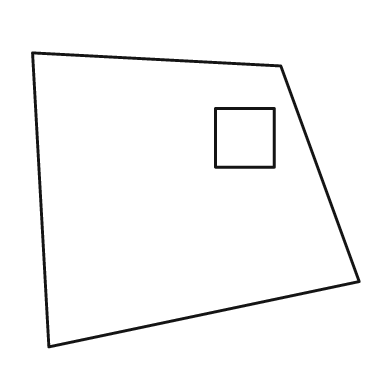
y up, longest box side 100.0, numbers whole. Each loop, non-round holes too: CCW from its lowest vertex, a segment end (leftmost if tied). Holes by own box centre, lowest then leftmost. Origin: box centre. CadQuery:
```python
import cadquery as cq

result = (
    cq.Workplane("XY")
    .moveTo(-45.0, -45.0)
    .lineTo(50.0, -25.0)
    .lineTo(26.0, 41.0)
    .lineTo(-50.0, 45.0)
    .close()
    .moveTo(6.0, 10.0)
    .lineTo(24.0, 10.0)
    .lineTo(24.0, 28.0)
    .lineTo(6.0, 28.0)
    .close()
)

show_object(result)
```